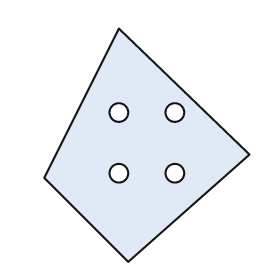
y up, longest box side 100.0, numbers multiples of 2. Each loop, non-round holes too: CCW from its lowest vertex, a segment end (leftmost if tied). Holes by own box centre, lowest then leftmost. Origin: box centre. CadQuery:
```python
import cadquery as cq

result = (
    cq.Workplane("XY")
    .moveTo(-8.0, -50.0)
    .lineTo(44.0, -4.0)
    .lineTo(-12.0, 50.0)
    .lineTo(-44.0, -14.0)
    .close()
    .moveTo(-12.0, -12.0)
    .circle(4.0)
    .moveTo(12.0, -12.0)
    .circle(4.0)
    .moveTo(-12.0, 14.0)
    .circle(4.0)
    .moveTo(12.0, 14.0)
    .circle(4.0)
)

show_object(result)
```